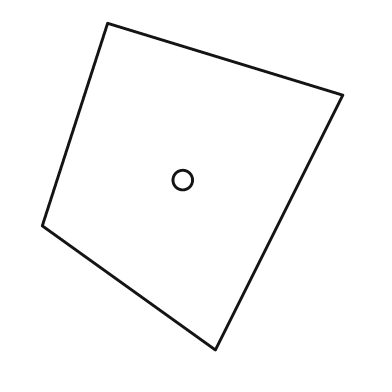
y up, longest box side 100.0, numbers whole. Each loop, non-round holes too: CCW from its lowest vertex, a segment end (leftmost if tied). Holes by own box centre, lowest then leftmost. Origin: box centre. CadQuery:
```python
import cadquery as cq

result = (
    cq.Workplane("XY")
    .moveTo(7.0, -50.0)
    .lineTo(46.0, 28.0)
    .lineTo(-26.0, 50.0)
    .lineTo(-46.0, -12.0)
    .close()
    .moveTo(-3.0, 2.0)
    .circle(3.0)
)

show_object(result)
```